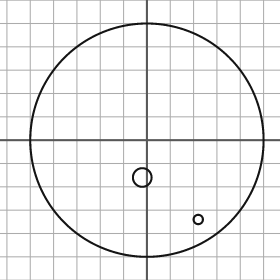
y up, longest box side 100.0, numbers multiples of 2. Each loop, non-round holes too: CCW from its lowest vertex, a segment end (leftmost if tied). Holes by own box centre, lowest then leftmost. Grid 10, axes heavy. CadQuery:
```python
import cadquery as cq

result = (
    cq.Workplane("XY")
    .moveTo(0.0, 0.0)
    .circle(50.0)
    .moveTo(22.0, -34.0)
    .circle(2.0)
    .moveTo(-2.0, -16.0)
    .circle(4.0)
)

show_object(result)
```